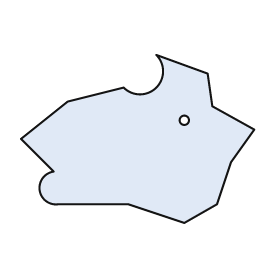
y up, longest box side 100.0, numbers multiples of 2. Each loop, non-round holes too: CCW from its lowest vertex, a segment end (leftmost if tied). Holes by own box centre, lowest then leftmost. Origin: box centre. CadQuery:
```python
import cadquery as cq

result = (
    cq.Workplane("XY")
    .moveTo(20.0, -36.0)
    .lineTo(34.0, -28.0)
    .lineTo(40.0, -10.0)
    .lineTo(50.0, 4.0)
    .lineTo(32.0, 14.0)
    .lineTo(30.0, 28.0)
    .lineTo(8.0, 36.0)
    .threePointArc((8.0, 22.0), (-6.0, 22.0))
    .lineTo(-30.0, 16.0)
    .lineTo(-50.0, 0.0)
    .lineTo(-36.0, -14.0)
    .threePointArc((-42.0, -22.0), (-34.0, -28.0))
    .lineTo(-4.0, -28.0)
    .close()
    .moveTo(20.0, 8.0)
    .circle(2.0)
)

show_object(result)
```